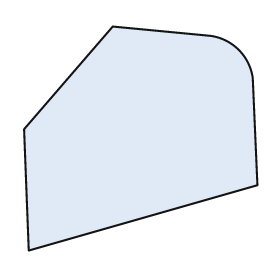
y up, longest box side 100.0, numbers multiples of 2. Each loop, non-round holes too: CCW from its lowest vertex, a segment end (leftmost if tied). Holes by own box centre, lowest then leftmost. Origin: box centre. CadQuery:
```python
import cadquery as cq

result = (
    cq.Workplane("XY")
    .moveTo(-48.0, -48.0)
    .lineTo(50.0, -20.0)
    .lineTo(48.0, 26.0)
    .threePointArc((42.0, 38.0), (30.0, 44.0))
    .lineTo(-12.0, 48.0)
    .lineTo(-50.0, 4.0)
    .close()
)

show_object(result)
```